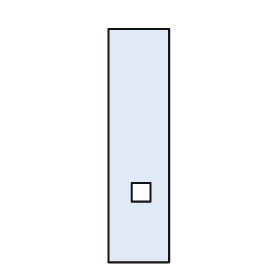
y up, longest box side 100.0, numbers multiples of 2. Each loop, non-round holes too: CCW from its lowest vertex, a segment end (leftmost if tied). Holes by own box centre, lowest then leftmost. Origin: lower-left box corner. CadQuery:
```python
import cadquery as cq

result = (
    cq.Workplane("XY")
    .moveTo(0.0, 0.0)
    .lineTo(26.0, 0.0)
    .lineTo(26.0, 100.0)
    .lineTo(0.0, 100.0)
    .close()
    .moveTo(10.0, 26.0)
    .lineTo(18.0, 26.0)
    .lineTo(18.0, 34.0)
    .lineTo(10.0, 34.0)
    .close()
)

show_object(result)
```